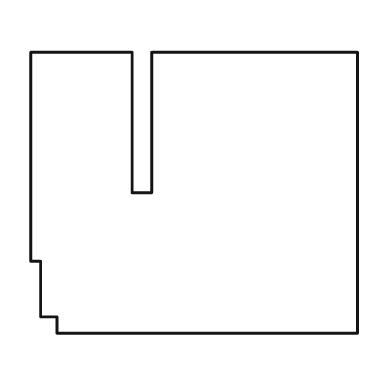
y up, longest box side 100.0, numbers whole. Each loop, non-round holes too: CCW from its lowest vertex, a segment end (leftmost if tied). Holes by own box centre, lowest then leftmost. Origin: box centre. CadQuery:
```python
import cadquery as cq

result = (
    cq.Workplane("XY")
    .moveTo(-42.0, -43.0)
    .lineTo(50.0, -43.0)
    .lineTo(50.0, 43.0)
    .lineTo(-13.0, 43.0)
    .lineTo(-13.0, 0.0)
    .lineTo(-19.0, 0.0)
    .lineTo(-19.0, 43.0)
    .lineTo(-50.0, 43.0)
    .lineTo(-50.0, -21.0)
    .lineTo(-47.0, -21.0)
    .lineTo(-47.0, -38.0)
    .lineTo(-42.0, -38.0)
    .close()
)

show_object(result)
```